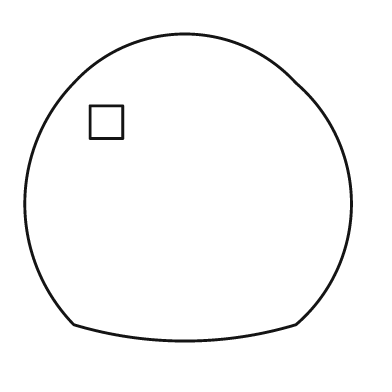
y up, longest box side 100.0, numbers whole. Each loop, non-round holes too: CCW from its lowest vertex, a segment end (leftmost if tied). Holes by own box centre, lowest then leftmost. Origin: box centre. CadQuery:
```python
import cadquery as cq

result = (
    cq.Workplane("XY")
    .moveTo(-35.0, -42.0)
    .threePointArc((-1.0, -47.0), (33.0, -42.0))
    .threePointArc((50.0, -5.0), (33.0, 32.0))
    .threePointArc((-1.0, 47.0), (-35.0, 32.0))
    .threePointArc((-50.0, -5.0), (-35.0, -42.0))
    .close()
    .moveTo(-30.0, 15.0)
    .lineTo(-20.0, 15.0)
    .lineTo(-20.0, 25.0)
    .lineTo(-30.0, 25.0)
    .close()
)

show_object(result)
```